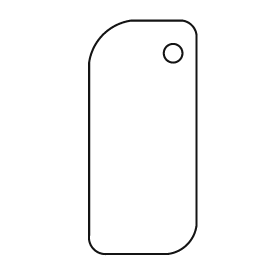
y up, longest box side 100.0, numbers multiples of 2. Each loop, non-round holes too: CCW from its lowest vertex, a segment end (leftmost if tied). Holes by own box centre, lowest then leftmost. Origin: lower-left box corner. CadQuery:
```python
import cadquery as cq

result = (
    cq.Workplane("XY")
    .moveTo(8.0, 0.0)
    .lineTo(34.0, 0.0)
    .threePointArc((42.0, 4.0), (46.0, 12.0))
    .lineTo(46.0, 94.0)
    .threePointArc((44.0, 98.0), (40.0, 100.0))
    .lineTo(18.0, 100.0)
    .threePointArc((6.0, 94.0), (0.0, 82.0))
    .lineTo(0.0, 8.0)
    .threePointArc((2.0, 2.0), (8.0, 0.0))
    .close()
    .moveTo(36.0, 86.0)
    .circle(4.0)
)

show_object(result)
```